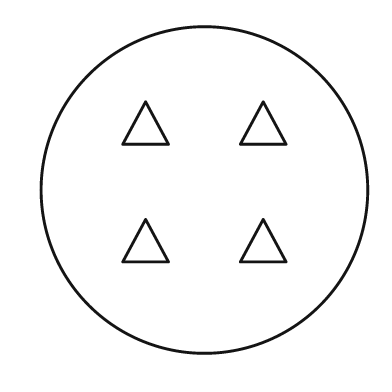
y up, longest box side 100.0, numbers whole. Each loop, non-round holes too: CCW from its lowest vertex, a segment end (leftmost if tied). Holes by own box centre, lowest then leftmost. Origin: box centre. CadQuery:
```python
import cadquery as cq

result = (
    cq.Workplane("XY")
    .moveTo(0.0, 0.0)
    .circle(50.0)
    .moveTo(-25.0, -22.0)
    .lineTo(-11.0, -22.0)
    .lineTo(-18.0, -9.0)
    .close()
    .moveTo(11.0, -22.0)
    .lineTo(25.0, -22.0)
    .lineTo(18.0, -9.0)
    .close()
    .moveTo(-25.0, 14.0)
    .lineTo(-11.0, 14.0)
    .lineTo(-18.0, 27.0)
    .close()
    .moveTo(11.0, 14.0)
    .lineTo(25.0, 14.0)
    .lineTo(18.0, 27.0)
    .close()
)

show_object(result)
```